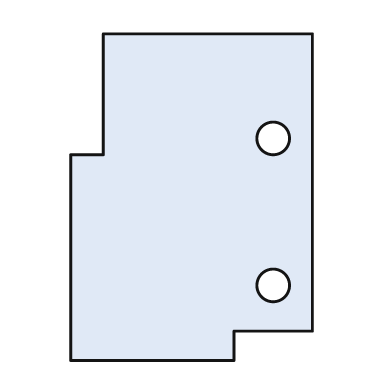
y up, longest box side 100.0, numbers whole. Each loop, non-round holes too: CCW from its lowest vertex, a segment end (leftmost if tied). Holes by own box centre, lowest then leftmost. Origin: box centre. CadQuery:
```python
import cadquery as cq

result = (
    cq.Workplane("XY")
    .moveTo(-37.0, -50.0)
    .lineTo(13.0, -50.0)
    .lineTo(13.0, -41.0)
    .lineTo(37.0, -41.0)
    .lineTo(37.0, 50.0)
    .lineTo(-27.0, 50.0)
    .lineTo(-27.0, 13.0)
    .lineTo(-37.0, 13.0)
    .close()
    .moveTo(25.0, -27.0)
    .circle(5.0)
    .moveTo(25.0, 18.0)
    .circle(5.0)
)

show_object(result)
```